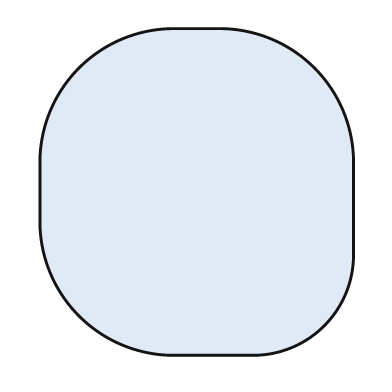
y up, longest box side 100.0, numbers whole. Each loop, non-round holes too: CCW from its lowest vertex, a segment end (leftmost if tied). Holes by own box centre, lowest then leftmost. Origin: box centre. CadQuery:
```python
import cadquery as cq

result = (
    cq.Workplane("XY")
    .moveTo(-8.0, -50.0)
    .lineTo(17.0, -50.0)
    .threePointArc((39.0, -41.0), (48.0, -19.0))
    .lineTo(48.0, 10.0)
    .threePointArc((36.0, 38.0), (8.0, 50.0))
    .lineTo(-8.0, 50.0)
    .threePointArc((-36.0, 38.0), (-48.0, 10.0))
    .lineTo(-48.0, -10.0)
    .threePointArc((-36.0, -38.0), (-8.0, -50.0))
    .close()
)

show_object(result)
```